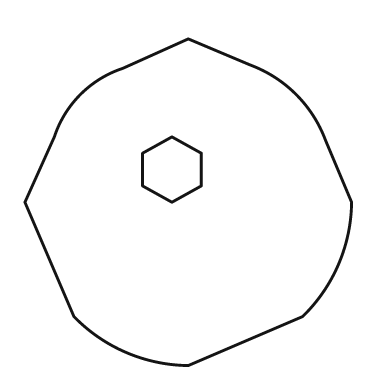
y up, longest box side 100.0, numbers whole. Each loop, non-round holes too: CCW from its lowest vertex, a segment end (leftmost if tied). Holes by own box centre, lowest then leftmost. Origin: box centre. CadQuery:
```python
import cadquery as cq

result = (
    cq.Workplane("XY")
    .moveTo(0.0, -50.0)
    .lineTo(35.0, -35.0)
    .threePointArc((46.0, -19.0), (50.0, 0.0))
    .lineTo(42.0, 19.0)
    .threePointArc((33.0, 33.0), (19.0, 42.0))
    .lineTo(0.0, 50.0)
    .lineTo(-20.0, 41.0)
    .threePointArc((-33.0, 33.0), (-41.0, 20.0))
    .lineTo(-50.0, 0.0)
    .lineTo(-35.0, -35.0)
    .threePointArc((-19.0, -46.0), (0.0, -50.0))
    .close()
    .moveTo(-5.0, 0.0)
    .lineTo(4.0, 5.0)
    .lineTo(4.0, 15.0)
    .lineTo(-5.0, 20.0)
    .lineTo(-14.0, 15.0)
    .lineTo(-14.0, 5.0)
    .close()
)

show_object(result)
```